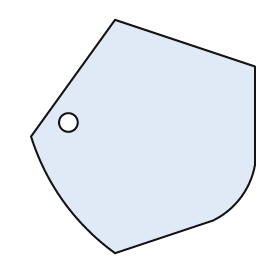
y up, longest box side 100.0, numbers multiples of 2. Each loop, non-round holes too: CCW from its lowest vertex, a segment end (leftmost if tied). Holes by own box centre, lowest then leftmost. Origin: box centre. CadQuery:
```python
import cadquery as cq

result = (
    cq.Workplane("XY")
    .moveTo(-12.0, -50.0)
    .lineTo(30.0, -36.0)
    .threePointArc((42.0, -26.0), (48.0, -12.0))
    .lineTo(48.0, 30.0)
    .lineTo(-12.0, 50.0)
    .lineTo(-48.0, 0.0)
    .threePointArc((-34.0, -28.0), (-12.0, -50.0))
    .close()
    .moveTo(-32.0, 6.0)
    .circle(4.0)
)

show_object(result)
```